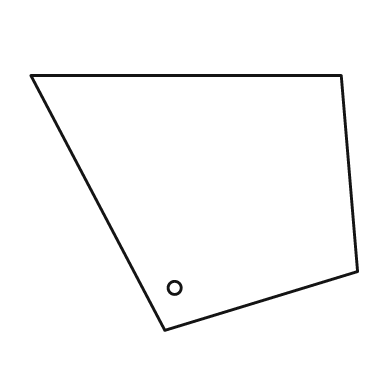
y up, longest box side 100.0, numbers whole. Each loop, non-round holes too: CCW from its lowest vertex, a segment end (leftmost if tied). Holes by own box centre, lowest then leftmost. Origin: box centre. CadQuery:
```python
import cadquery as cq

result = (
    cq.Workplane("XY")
    .moveTo(-9.0, -39.0)
    .lineTo(50.0, -21.0)
    .lineTo(45.0, 39.0)
    .lineTo(-50.0, 39.0)
    .close()
    .moveTo(-6.0, -26.0)
    .circle(2.0)
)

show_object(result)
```